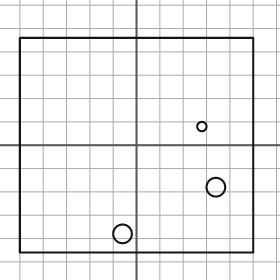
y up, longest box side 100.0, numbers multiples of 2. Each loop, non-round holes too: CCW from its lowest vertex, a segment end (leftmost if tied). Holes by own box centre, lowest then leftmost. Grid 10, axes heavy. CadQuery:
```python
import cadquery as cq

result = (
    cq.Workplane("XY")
    .moveTo(-50.0, -46.0)
    .lineTo(50.0, -46.0)
    .lineTo(50.0, 46.0)
    .lineTo(-50.0, 46.0)
    .close()
    .moveTo(-6.0, -38.0)
    .circle(4.0)
    .moveTo(34.0, -18.0)
    .circle(4.0)
    .moveTo(28.0, 8.0)
    .circle(2.0)
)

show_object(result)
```